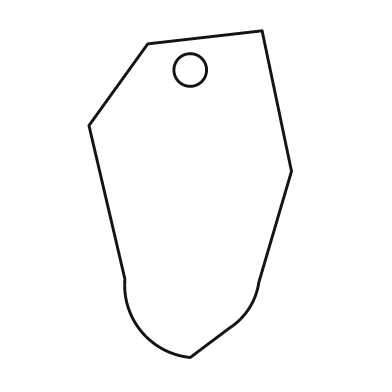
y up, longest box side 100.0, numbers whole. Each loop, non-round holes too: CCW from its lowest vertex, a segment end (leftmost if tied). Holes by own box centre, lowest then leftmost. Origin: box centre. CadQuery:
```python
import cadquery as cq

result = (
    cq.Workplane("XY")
    .moveTo(0.0, -50.0)
    .lineTo(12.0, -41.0)
    .threePointArc((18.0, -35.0), (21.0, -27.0))
    .lineTo(31.0, 7.0)
    .lineTo(22.0, 50.0)
    .lineTo(-13.0, 46.0)
    .lineTo(-31.0, 21.0)
    .lineTo(-20.0, -26.0)
    .threePointArc((-15.0, -42.0), (0.0, -50.0))
    .close()
    .moveTo(0.0, 38.0)
    .circle(5.0)
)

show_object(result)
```